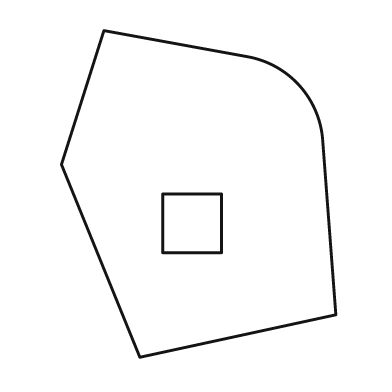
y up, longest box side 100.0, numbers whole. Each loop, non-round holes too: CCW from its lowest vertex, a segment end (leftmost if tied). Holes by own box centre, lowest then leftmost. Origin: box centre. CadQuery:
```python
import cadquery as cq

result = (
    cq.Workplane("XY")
    .moveTo(-18.0, -50.0)
    .lineTo(42.0, -37.0)
    .lineTo(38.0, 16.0)
    .threePointArc((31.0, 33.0), (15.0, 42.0))
    .lineTo(-29.0, 50.0)
    .lineTo(-42.0, 9.0)
    .close()
    .moveTo(-11.0, -18.0)
    .lineTo(7.0, -18.0)
    .lineTo(7.0, 0.0)
    .lineTo(-11.0, 0.0)
    .close()
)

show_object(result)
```